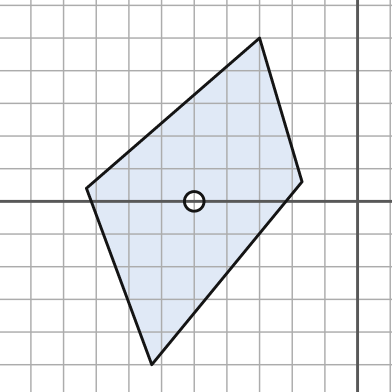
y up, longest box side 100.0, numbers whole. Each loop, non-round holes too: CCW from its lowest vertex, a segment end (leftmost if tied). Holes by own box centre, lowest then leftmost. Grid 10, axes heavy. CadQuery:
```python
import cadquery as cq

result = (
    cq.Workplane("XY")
    .moveTo(-63.0, -50.0)
    .lineTo(-17.0, 6.0)
    .lineTo(-30.0, 50.0)
    .lineTo(-83.0, 4.0)
    .close()
    .moveTo(-50.0, 0.0)
    .circle(3.0)
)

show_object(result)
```